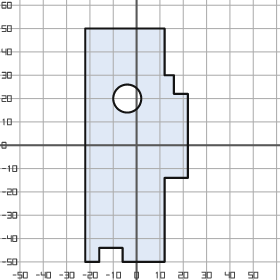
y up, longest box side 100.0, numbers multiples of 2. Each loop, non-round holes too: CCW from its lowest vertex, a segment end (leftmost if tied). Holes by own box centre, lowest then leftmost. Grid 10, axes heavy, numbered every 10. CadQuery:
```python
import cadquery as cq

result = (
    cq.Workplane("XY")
    .moveTo(-22.0, -50.0)
    .lineTo(-16.0, -50.0)
    .lineTo(-16.0, -44.0)
    .lineTo(-6.0, -44.0)
    .lineTo(-6.0, -50.0)
    .lineTo(12.0, -50.0)
    .lineTo(12.0, -14.0)
    .lineTo(22.0, -14.0)
    .lineTo(22.0, 22.0)
    .lineTo(16.0, 22.0)
    .lineTo(16.0, 30.0)
    .lineTo(12.0, 30.0)
    .lineTo(12.0, 50.0)
    .lineTo(-22.0, 50.0)
    .close()
    .moveTo(-4.0, 20.0)
    .circle(6.0)
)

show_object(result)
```